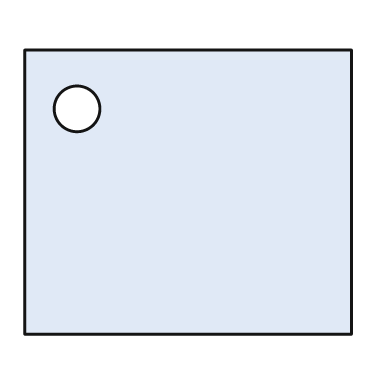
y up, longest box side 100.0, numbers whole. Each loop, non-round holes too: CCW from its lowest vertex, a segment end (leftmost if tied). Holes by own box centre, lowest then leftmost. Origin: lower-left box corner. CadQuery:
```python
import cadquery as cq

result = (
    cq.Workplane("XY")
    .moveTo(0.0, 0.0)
    .lineTo(100.0, 0.0)
    .lineTo(100.0, 87.0)
    .lineTo(0.0, 87.0)
    .close()
    .moveTo(16.0, 69.0)
    .circle(7.0)
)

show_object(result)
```